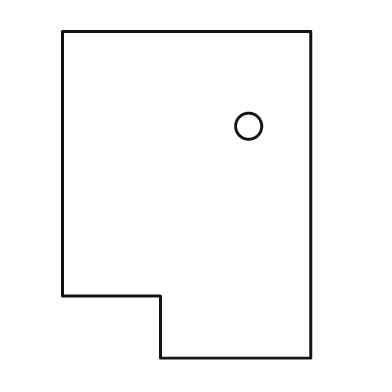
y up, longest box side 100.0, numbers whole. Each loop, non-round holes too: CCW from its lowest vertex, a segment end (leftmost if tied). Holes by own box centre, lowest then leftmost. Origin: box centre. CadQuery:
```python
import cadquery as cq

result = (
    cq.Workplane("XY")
    .moveTo(-8.0, -50.0)
    .lineTo(38.0, -50.0)
    .lineTo(38.0, 50.0)
    .lineTo(-38.0, 50.0)
    .lineTo(-38.0, -31.0)
    .lineTo(-8.0, -31.0)
    .close()
    .moveTo(19.0, 21.0)
    .circle(4.0)
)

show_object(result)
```